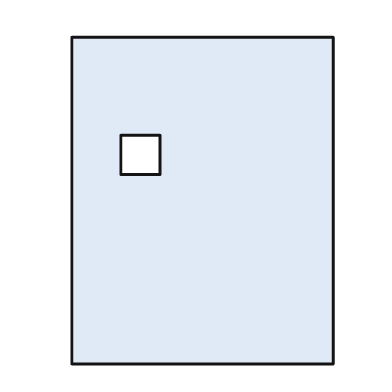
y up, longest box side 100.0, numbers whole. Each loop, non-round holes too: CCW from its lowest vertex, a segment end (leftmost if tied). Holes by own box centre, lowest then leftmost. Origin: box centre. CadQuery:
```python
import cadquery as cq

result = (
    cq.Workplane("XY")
    .moveTo(-40.0, -50.0)
    .lineTo(40.0, -50.0)
    .lineTo(40.0, 50.0)
    .lineTo(-40.0, 50.0)
    .close()
    .moveTo(-25.0, 8.0)
    .lineTo(-13.0, 8.0)
    .lineTo(-13.0, 20.0)
    .lineTo(-25.0, 20.0)
    .close()
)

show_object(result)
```